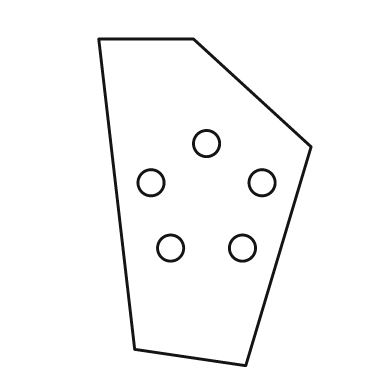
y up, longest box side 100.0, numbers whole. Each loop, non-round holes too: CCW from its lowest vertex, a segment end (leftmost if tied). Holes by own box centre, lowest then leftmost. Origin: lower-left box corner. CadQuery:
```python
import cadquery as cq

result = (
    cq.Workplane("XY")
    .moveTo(45.0, 0.0)
    .lineTo(65.0, 67.0)
    .lineTo(29.0, 100.0)
    .lineTo(0.0, 100.0)
    .lineTo(11.0, 5.0)
    .close()
    .moveTo(22.0, 36.0)
    .circle(4.0)
    .moveTo(44.0, 36.0)
    .circle(4.0)
    .moveTo(16.0, 56.0)
    .circle(4.0)
    .moveTo(50.0, 56.0)
    .circle(4.0)
    .moveTo(33.0, 68.0)
    .circle(4.0)
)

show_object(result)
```